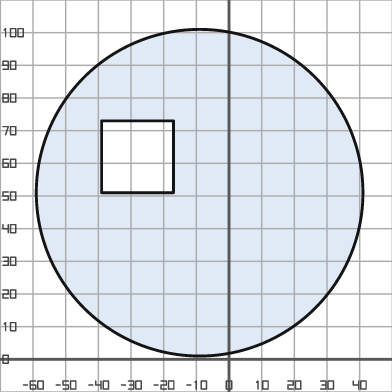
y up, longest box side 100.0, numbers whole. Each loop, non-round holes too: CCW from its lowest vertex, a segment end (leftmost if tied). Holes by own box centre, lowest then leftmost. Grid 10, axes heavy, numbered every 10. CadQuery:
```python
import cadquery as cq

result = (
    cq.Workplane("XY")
    .moveTo(-9.0, 51.0)
    .circle(50.0)
    .moveTo(-39.0, 51.0)
    .lineTo(-17.0, 51.0)
    .lineTo(-17.0, 73.0)
    .lineTo(-39.0, 73.0)
    .close()
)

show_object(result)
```